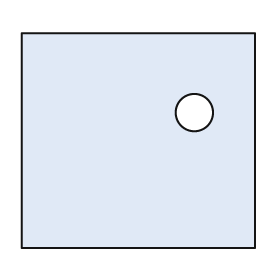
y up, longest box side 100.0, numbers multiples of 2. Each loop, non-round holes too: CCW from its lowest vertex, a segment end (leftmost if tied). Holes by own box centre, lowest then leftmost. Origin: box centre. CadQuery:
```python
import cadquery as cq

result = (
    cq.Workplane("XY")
    .moveTo(-50.0, -46.0)
    .lineTo(50.0, -46.0)
    .lineTo(50.0, 46.0)
    .lineTo(-50.0, 46.0)
    .close()
    .moveTo(24.0, 12.0)
    .circle(8.0)
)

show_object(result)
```